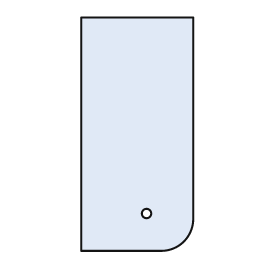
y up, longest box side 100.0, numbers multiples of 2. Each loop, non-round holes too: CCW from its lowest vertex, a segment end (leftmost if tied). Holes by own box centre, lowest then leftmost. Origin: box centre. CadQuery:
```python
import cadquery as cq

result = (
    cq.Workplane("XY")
    .moveTo(-24.0, -50.0)
    .lineTo(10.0, -50.0)
    .threePointArc((20.0, -46.0), (24.0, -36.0))
    .lineTo(24.0, 50.0)
    .lineTo(-24.0, 50.0)
    .close()
    .moveTo(4.0, -34.0)
    .circle(2.0)
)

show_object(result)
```